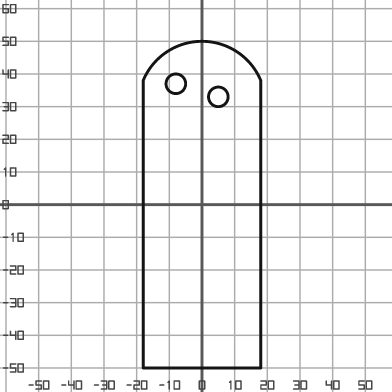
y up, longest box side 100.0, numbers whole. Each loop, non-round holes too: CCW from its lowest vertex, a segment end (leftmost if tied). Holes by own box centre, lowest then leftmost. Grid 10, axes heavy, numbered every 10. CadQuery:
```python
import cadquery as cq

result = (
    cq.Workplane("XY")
    .moveTo(-18.0, -50.0)
    .lineTo(18.0, -50.0)
    .lineTo(18.0, 38.0)
    .threePointArc((0.0, 50.0), (-18.0, 38.0))
    .close()
    .moveTo(5.0, 33.0)
    .circle(3.0)
    .moveTo(-8.0, 37.0)
    .circle(3.0)
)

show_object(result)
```